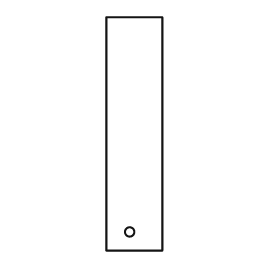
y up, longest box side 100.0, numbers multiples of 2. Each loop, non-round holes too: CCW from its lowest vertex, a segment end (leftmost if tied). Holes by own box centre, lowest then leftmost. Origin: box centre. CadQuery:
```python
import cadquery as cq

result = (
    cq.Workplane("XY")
    .moveTo(-12.0, -50.0)
    .lineTo(12.0, -50.0)
    .lineTo(12.0, 50.0)
    .lineTo(-12.0, 50.0)
    .close()
    .moveTo(-2.0, -42.0)
    .circle(2.0)
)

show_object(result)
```